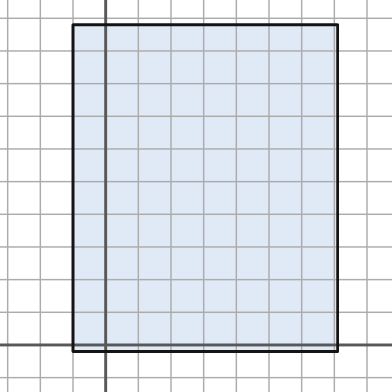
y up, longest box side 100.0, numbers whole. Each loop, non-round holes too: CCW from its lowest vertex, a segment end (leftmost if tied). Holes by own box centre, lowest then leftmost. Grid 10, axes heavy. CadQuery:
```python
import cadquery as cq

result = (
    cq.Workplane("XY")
    .moveTo(-10.0, -2.0)
    .lineTo(71.0, -2.0)
    .lineTo(71.0, 98.0)
    .lineTo(-10.0, 98.0)
    .close()
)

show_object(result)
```